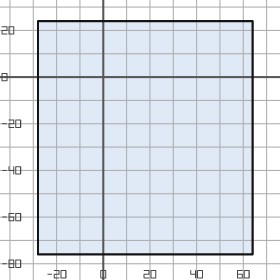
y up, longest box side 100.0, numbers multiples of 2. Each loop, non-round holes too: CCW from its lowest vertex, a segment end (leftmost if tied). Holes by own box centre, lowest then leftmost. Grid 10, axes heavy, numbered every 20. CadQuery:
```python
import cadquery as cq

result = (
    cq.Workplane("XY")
    .moveTo(-28.0, -76.0)
    .lineTo(64.0, -76.0)
    .lineTo(64.0, 24.0)
    .lineTo(-28.0, 24.0)
    .close()
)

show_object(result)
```